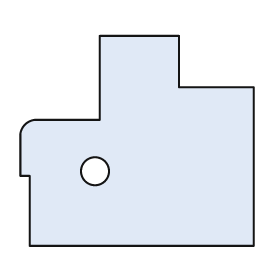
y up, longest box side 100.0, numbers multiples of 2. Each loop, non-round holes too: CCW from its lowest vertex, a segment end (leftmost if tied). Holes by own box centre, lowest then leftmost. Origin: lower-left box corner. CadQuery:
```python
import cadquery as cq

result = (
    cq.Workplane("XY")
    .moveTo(4.0, 0.0)
    .lineTo(100.0, 0.0)
    .lineTo(100.0, 68.0)
    .lineTo(68.0, 68.0)
    .lineTo(68.0, 90.0)
    .lineTo(34.0, 90.0)
    .lineTo(34.0, 54.0)
    .lineTo(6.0, 54.0)
    .threePointArc((2.0, 52.0), (0.0, 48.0))
    .lineTo(0.0, 30.0)
    .lineTo(4.0, 30.0)
    .close()
    .moveTo(32.0, 32.0)
    .circle(6.0)
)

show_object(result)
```